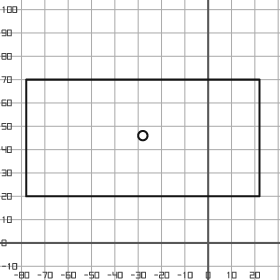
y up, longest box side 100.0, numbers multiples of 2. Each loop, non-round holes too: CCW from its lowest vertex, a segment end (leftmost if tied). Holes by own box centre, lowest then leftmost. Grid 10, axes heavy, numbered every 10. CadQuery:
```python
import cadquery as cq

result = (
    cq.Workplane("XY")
    .moveTo(-78.0, 20.0)
    .lineTo(22.0, 20.0)
    .lineTo(22.0, 70.0)
    .lineTo(-78.0, 70.0)
    .close()
    .moveTo(-28.0, 46.0)
    .circle(2.0)
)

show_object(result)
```